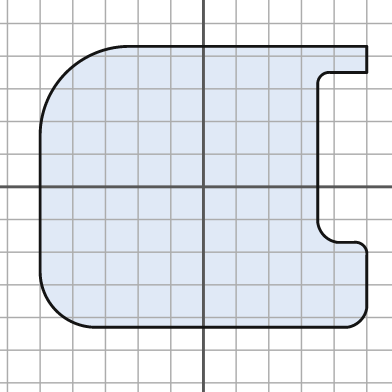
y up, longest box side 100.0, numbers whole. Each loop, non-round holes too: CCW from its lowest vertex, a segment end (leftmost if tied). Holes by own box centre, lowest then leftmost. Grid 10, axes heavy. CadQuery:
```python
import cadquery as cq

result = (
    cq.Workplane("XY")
    .moveTo(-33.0, -43.0)
    .lineTo(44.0, -43.0)
    .threePointArc((48.0, -41.0), (50.0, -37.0))
    .lineTo(50.0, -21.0)
    .threePointArc((49.0, -18.0), (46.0, -17.0))
    .lineTo(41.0, -17.0)
    .threePointArc((37.0, -15.0), (35.0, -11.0))
    .lineTo(35.0, 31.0)
    .threePointArc((36.0, 34.0), (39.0, 35.0))
    .lineTo(50.0, 35.0)
    .lineTo(50.0, 43.0)
    .lineTo(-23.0, 43.0)
    .threePointArc((-42.0, 35.0), (-50.0, 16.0))
    .lineTo(-50.0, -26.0)
    .threePointArc((-45.0, -38.0), (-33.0, -43.0))
    .close()
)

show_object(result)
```